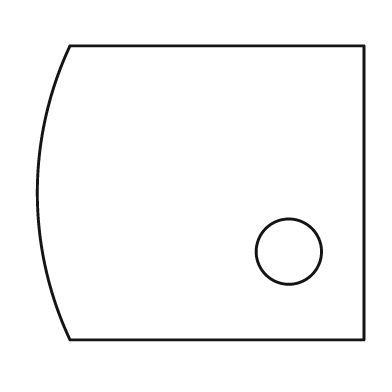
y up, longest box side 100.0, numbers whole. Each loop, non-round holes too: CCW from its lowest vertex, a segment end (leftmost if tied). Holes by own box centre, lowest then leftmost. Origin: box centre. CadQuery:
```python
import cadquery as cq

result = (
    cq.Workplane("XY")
    .moveTo(-40.0, -45.0)
    .lineTo(50.0, -45.0)
    .lineTo(50.0, 45.0)
    .lineTo(-40.0, 45.0)
    .threePointArc((-50.0, 0.0), (-40.0, -45.0))
    .close()
    .moveTo(27.0, -18.0)
    .circle(10.0)
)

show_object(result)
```